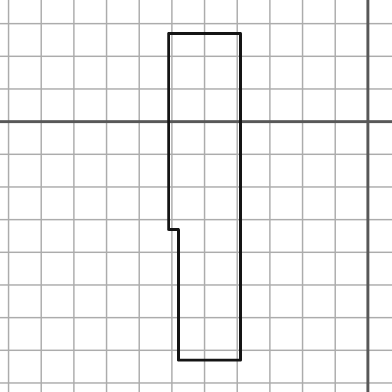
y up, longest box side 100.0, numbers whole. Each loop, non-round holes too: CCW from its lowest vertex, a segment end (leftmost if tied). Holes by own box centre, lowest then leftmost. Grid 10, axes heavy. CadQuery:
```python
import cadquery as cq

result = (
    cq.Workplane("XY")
    .moveTo(-58.0, -73.0)
    .lineTo(-39.0, -73.0)
    .lineTo(-39.0, 27.0)
    .lineTo(-61.0, 27.0)
    .lineTo(-61.0, -33.0)
    .lineTo(-58.0, -33.0)
    .close()
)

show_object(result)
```